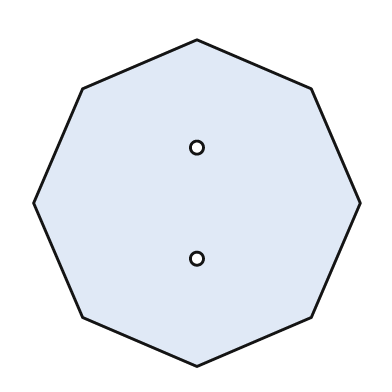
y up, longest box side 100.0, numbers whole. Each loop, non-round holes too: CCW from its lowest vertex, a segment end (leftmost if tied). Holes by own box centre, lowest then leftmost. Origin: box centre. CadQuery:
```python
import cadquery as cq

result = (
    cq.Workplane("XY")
    .moveTo(0.0, -50.0)
    .lineTo(35.0, -35.0)
    .lineTo(50.0, 0.0)
    .lineTo(35.0, 35.0)
    .lineTo(0.0, 50.0)
    .lineTo(-35.0, 35.0)
    .lineTo(-50.0, 0.0)
    .lineTo(-35.0, -35.0)
    .close()
    .moveTo(0.0, -17.0)
    .circle(2.0)
    .moveTo(0.0, 17.0)
    .circle(2.0)
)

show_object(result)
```